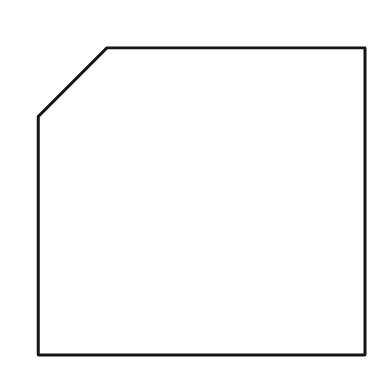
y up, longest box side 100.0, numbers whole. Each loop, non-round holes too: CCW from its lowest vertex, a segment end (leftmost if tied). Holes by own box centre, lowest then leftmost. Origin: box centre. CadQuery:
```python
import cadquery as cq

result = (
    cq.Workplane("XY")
    .moveTo(-50.0, -47.0)
    .lineTo(50.0, -47.0)
    .lineTo(50.0, 47.0)
    .lineTo(-29.0, 47.0)
    .lineTo(-50.0, 26.0)
    .close()
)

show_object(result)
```